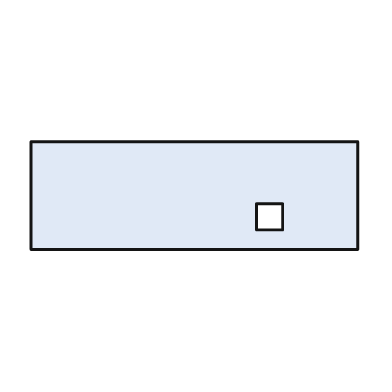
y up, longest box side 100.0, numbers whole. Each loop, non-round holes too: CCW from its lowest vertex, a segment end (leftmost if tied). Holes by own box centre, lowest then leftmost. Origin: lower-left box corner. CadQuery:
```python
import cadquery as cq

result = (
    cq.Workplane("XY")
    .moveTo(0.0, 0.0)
    .lineTo(100.0, 0.0)
    .lineTo(100.0, 33.0)
    .lineTo(0.0, 33.0)
    .close()
    .moveTo(69.0, 6.0)
    .lineTo(77.0, 6.0)
    .lineTo(77.0, 14.0)
    .lineTo(69.0, 14.0)
    .close()
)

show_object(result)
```